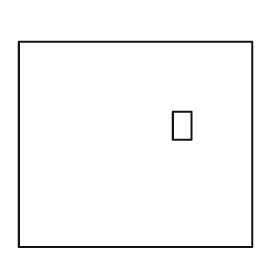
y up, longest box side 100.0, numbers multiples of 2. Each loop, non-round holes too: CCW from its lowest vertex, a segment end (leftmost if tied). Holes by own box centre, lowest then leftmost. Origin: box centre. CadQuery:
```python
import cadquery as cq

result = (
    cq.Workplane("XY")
    .moveTo(-50.0, -44.0)
    .lineTo(50.0, -44.0)
    .lineTo(50.0, 44.0)
    .lineTo(-50.0, 44.0)
    .close()
    .moveTo(16.0, 2.0)
    .lineTo(24.0, 2.0)
    .lineTo(24.0, 14.0)
    .lineTo(16.0, 14.0)
    .close()
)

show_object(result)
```